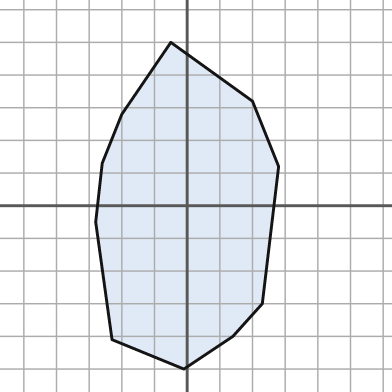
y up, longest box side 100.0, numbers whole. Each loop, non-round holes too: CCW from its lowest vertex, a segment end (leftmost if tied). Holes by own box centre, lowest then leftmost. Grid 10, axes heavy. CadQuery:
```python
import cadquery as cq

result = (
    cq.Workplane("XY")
    .moveTo(-1.0, -50.0)
    .lineTo(14.0, -40.0)
    .lineTo(23.0, -30.0)
    .lineTo(28.0, 12.0)
    .lineTo(20.0, 32.0)
    .lineTo(-5.0, 50.0)
    .lineTo(-20.0, 28.0)
    .lineTo(-26.0, 13.0)
    .lineTo(-28.0, -5.0)
    .lineTo(-23.0, -41.0)
    .close()
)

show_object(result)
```